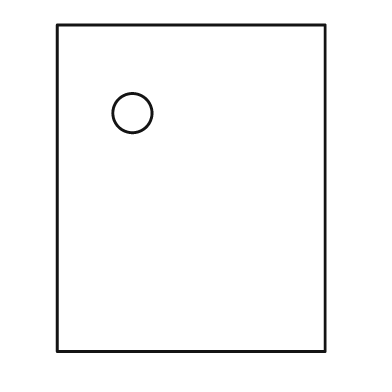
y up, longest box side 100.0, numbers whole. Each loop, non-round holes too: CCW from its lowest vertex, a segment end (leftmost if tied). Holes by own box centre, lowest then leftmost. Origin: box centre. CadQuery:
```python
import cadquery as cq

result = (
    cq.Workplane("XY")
    .moveTo(-41.0, -50.0)
    .lineTo(41.0, -50.0)
    .lineTo(41.0, 50.0)
    .lineTo(-41.0, 50.0)
    .close()
    .moveTo(-18.0, 23.0)
    .circle(6.0)
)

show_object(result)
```